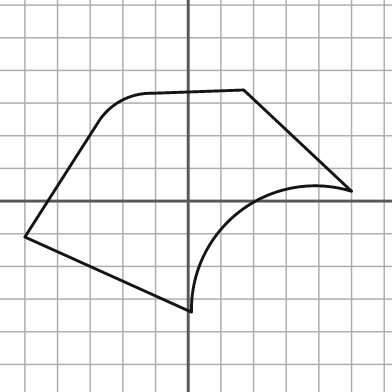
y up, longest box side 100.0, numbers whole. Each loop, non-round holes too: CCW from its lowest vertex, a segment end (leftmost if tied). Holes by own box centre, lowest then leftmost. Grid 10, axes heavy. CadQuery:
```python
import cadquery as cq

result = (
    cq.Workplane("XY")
    .moveTo(1.0, -34.0)
    .threePointArc((16.0, -3.0), (50.0, 3.0))
    .lineTo(17.0, 34.0)
    .lineTo(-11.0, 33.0)
    .threePointArc((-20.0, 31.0), (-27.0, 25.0))
    .lineTo(-50.0, -11.0)
    .close()
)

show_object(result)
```